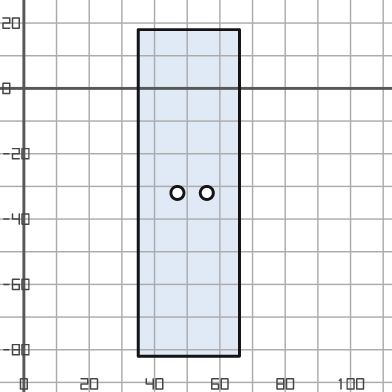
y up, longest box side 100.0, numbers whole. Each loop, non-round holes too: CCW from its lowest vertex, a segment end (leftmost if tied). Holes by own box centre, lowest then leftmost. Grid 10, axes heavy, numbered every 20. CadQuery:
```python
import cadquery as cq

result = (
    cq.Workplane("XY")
    .moveTo(35.0, -82.0)
    .lineTo(66.0, -82.0)
    .lineTo(66.0, 18.0)
    .lineTo(35.0, 18.0)
    .close()
    .moveTo(47.0, -32.0)
    .circle(2.0)
    .moveTo(56.0, -32.0)
    .circle(2.0)
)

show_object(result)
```